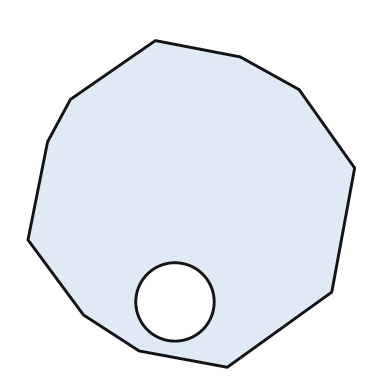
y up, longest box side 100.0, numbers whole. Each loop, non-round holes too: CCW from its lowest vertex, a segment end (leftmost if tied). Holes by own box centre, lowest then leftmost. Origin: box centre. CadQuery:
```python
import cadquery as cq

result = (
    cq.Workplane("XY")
    .moveTo(11.0, -50.0)
    .lineTo(43.0, -27.0)
    .lineTo(50.0, 11.0)
    .lineTo(33.0, 35.0)
    .lineTo(15.0, 45.0)
    .lineTo(-11.0, 50.0)
    .lineTo(-37.0, 32.0)
    .lineTo(-44.0, 19.0)
    .lineTo(-50.0, -11.0)
    .lineTo(-33.0, -34.0)
    .lineTo(-16.0, -45.0)
    .close()
    .moveTo(-5.0, -30.0)
    .circle(12.0)
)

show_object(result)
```